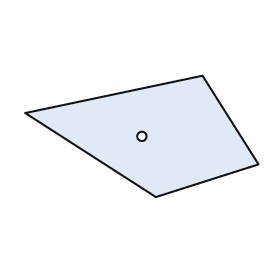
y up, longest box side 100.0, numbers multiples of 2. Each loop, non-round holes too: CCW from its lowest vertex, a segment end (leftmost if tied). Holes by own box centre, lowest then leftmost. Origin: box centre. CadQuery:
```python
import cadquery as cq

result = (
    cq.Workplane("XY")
    .moveTo(6.0, -26.0)
    .lineTo(50.0, -12.0)
    .lineTo(26.0, 26.0)
    .lineTo(-50.0, 10.0)
    .close()
    .moveTo(0.0, 0.0)
    .circle(2.0)
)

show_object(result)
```